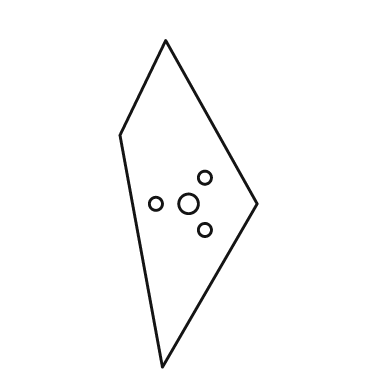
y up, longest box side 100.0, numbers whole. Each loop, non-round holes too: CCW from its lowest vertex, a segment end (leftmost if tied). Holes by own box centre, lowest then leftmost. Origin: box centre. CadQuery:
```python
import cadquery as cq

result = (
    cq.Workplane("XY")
    .moveTo(-8.0, -50.0)
    .lineTo(21.0, 0.0)
    .lineTo(-7.0, 50.0)
    .lineTo(-21.0, 21.0)
    .close()
    .moveTo(5.0, -8.0)
    .circle(2.0)
    .moveTo(-10.0, 0.0)
    .circle(2.0)
    .moveTo(0.0, 0.0)
    .circle(3.0)
    .moveTo(5.0, 8.0)
    .circle(2.0)
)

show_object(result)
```